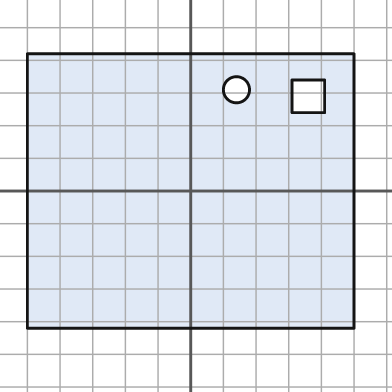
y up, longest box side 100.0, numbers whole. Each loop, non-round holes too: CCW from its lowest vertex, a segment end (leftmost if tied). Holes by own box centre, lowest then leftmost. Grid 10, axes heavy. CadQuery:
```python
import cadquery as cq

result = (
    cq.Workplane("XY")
    .moveTo(-50.0, -42.0)
    .lineTo(50.0, -42.0)
    .lineTo(50.0, 42.0)
    .lineTo(-50.0, 42.0)
    .close()
    .moveTo(31.0, 24.0)
    .lineTo(41.0, 24.0)
    .lineTo(41.0, 34.0)
    .lineTo(31.0, 34.0)
    .close()
    .moveTo(14.0, 31.0)
    .circle(4.0)
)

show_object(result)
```